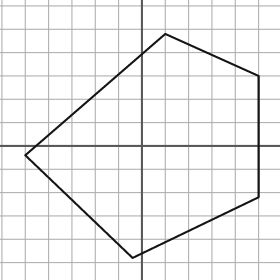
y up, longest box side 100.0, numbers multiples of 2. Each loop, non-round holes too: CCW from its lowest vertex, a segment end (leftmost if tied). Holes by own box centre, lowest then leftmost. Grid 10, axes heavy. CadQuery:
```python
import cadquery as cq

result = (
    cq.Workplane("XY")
    .moveTo(-4.0, -48.0)
    .lineTo(50.0, -22.0)
    .lineTo(50.0, 30.0)
    .lineTo(10.0, 48.0)
    .lineTo(-50.0, -4.0)
    .close()
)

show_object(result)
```